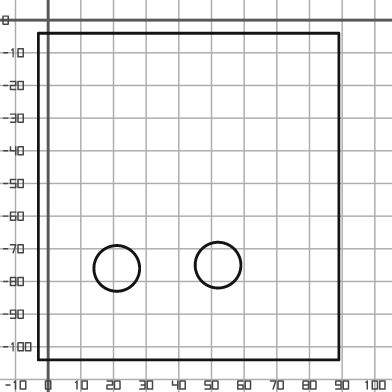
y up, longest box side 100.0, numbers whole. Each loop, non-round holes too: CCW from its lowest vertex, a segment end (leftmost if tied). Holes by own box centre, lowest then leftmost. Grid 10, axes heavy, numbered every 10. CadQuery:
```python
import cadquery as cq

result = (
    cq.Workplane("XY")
    .moveTo(-3.0, -104.0)
    .lineTo(89.0, -104.0)
    .lineTo(89.0, -4.0)
    .lineTo(-3.0, -4.0)
    .close()
    .moveTo(21.0, -76.0)
    .circle(7.0)
    .moveTo(52.0, -75.0)
    .circle(7.0)
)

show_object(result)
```